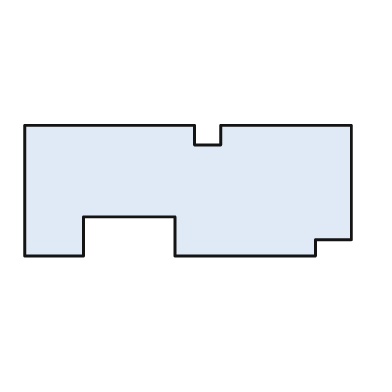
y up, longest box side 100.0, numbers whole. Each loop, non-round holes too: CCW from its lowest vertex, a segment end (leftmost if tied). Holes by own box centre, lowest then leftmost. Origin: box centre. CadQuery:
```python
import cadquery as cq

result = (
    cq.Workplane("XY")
    .moveTo(-50.0, -20.0)
    .lineTo(-32.0, -20.0)
    .lineTo(-32.0, -8.0)
    .lineTo(-4.0, -8.0)
    .lineTo(-4.0, -20.0)
    .lineTo(39.0, -20.0)
    .lineTo(39.0, -15.0)
    .lineTo(50.0, -15.0)
    .lineTo(50.0, 20.0)
    .lineTo(10.0, 20.0)
    .lineTo(10.0, 14.0)
    .lineTo(2.0, 14.0)
    .lineTo(2.0, 20.0)
    .lineTo(-50.0, 20.0)
    .close()
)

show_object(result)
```